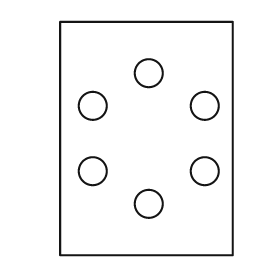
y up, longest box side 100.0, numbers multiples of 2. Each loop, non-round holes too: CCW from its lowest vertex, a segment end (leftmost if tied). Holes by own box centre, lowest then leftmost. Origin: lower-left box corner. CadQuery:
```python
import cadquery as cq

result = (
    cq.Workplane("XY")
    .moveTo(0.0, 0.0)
    .lineTo(74.0, 0.0)
    .lineTo(74.0, 100.0)
    .lineTo(0.0, 100.0)
    .close()
    .moveTo(38.0, 22.0)
    .circle(6.0)
    .moveTo(14.0, 36.0)
    .circle(6.0)
    .moveTo(62.0, 36.0)
    .circle(6.0)
    .moveTo(14.0, 64.0)
    .circle(6.0)
    .moveTo(62.0, 64.0)
    .circle(6.0)
    .moveTo(38.0, 78.0)
    .circle(6.0)
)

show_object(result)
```